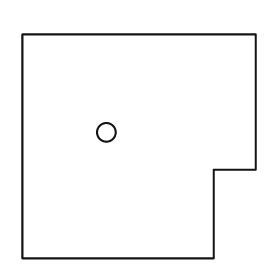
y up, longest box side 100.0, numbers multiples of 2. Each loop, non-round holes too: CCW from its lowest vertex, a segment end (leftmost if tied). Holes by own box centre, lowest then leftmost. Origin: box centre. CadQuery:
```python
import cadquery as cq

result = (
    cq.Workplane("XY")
    .moveTo(-50.0, -48.0)
    .lineTo(32.0, -48.0)
    .lineTo(32.0, -10.0)
    .lineTo(50.0, -10.0)
    .lineTo(50.0, 48.0)
    .lineTo(-50.0, 48.0)
    .close()
    .moveTo(-14.0, 6.0)
    .circle(4.0)
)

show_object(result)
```